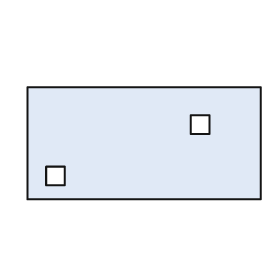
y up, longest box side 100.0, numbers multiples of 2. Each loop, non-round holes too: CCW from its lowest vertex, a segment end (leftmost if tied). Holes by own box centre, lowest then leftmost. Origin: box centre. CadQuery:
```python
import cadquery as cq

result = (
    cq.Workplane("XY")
    .moveTo(-50.0, -24.0)
    .lineTo(50.0, -24.0)
    .lineTo(50.0, 24.0)
    .lineTo(-50.0, 24.0)
    .close()
    .moveTo(-42.0, -18.0)
    .lineTo(-34.0, -18.0)
    .lineTo(-34.0, -10.0)
    .lineTo(-42.0, -10.0)
    .close()
    .moveTo(20.0, 4.0)
    .lineTo(28.0, 4.0)
    .lineTo(28.0, 12.0)
    .lineTo(20.0, 12.0)
    .close()
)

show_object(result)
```